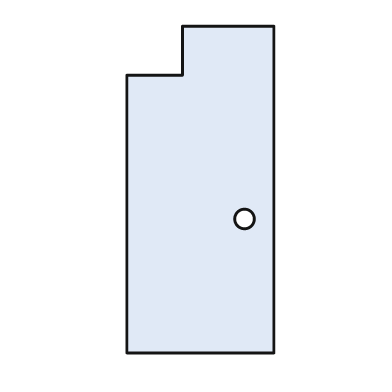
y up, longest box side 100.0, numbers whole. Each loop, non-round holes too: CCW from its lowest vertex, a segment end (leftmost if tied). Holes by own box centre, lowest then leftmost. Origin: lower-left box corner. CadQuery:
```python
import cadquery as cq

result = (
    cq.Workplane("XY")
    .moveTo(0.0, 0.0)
    .lineTo(45.0, 0.0)
    .lineTo(45.0, 100.0)
    .lineTo(17.0, 100.0)
    .lineTo(17.0, 85.0)
    .lineTo(0.0, 85.0)
    .close()
    .moveTo(36.0, 41.0)
    .circle(3.0)
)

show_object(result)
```